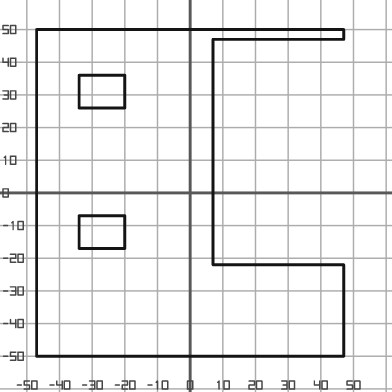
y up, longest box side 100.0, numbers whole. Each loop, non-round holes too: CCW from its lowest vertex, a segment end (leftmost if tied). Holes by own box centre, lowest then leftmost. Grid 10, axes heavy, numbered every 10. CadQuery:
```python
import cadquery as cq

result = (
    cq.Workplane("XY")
    .moveTo(-47.0, -50.0)
    .lineTo(47.0, -50.0)
    .lineTo(47.0, -22.0)
    .lineTo(7.0, -22.0)
    .lineTo(7.0, 47.0)
    .lineTo(47.0, 47.0)
    .lineTo(47.0, 50.0)
    .lineTo(-47.0, 50.0)
    .close()
    .moveTo(-34.0, -17.0)
    .lineTo(-20.0, -17.0)
    .lineTo(-20.0, -7.0)
    .lineTo(-34.0, -7.0)
    .close()
    .moveTo(-34.0, 26.0)
    .lineTo(-20.0, 26.0)
    .lineTo(-20.0, 36.0)
    .lineTo(-34.0, 36.0)
    .close()
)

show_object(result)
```